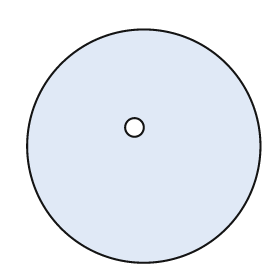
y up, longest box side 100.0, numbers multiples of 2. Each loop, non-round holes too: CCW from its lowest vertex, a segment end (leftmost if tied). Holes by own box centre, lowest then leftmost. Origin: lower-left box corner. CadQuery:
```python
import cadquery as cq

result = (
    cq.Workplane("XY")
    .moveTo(50.0, 50.0)
    .circle(50.0)
    .moveTo(46.0, 58.0)
    .circle(4.0)
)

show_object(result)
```